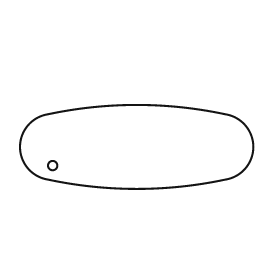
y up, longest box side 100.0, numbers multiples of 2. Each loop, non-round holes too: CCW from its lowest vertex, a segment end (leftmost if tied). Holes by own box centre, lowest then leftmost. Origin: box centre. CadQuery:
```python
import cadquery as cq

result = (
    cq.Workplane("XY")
    .moveTo(-38.0, -14.0)
    .threePointArc((0.0, -18.0), (38.0, -14.0))
    .threePointArc((50.0, 0.0), (38.0, 14.0))
    .threePointArc((0.0, 18.0), (-38.0, 14.0))
    .threePointArc((-50.0, 0.0), (-38.0, -14.0))
    .close()
    .moveTo(-36.0, -8.0)
    .circle(2.0)
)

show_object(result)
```